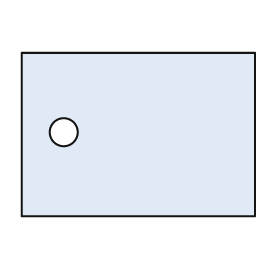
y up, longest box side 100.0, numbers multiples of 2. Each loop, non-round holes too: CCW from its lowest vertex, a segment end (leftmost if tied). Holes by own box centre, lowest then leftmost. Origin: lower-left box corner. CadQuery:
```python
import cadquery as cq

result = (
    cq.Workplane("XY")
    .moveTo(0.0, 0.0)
    .lineTo(100.0, 0.0)
    .lineTo(100.0, 70.0)
    .lineTo(0.0, 70.0)
    .close()
    .moveTo(18.0, 36.0)
    .circle(6.0)
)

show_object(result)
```